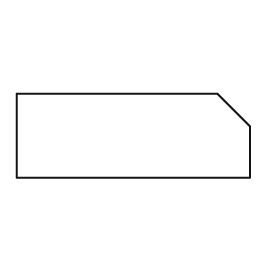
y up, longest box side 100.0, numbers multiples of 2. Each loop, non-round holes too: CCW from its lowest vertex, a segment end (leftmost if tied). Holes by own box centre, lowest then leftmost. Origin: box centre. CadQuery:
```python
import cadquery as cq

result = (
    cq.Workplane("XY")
    .moveTo(-50.0, -18.0)
    .lineTo(50.0, -18.0)
    .lineTo(50.0, 4.0)
    .lineTo(36.0, 18.0)
    .lineTo(-50.0, 18.0)
    .close()
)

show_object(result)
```